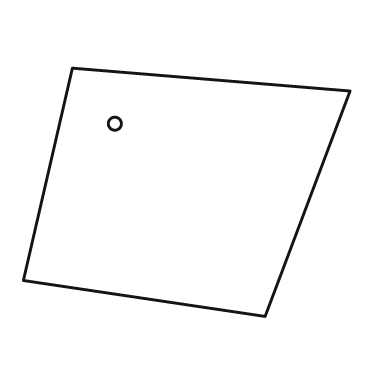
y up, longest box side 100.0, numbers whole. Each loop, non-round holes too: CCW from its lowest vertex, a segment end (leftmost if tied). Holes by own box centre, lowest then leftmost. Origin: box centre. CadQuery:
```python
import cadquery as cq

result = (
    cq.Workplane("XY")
    .moveTo(24.0, -38.0)
    .lineTo(50.0, 31.0)
    .lineTo(-35.0, 38.0)
    .lineTo(-50.0, -27.0)
    .close()
    .moveTo(-22.0, 21.0)
    .circle(2.0)
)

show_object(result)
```